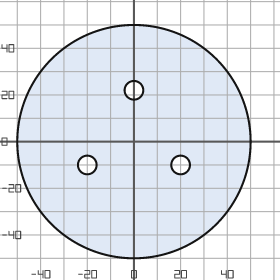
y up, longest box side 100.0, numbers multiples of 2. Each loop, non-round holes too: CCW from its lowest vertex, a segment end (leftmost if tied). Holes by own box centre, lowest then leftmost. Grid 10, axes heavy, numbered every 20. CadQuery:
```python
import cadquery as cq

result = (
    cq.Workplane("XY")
    .moveTo(0.0, 0.0)
    .circle(50.0)
    .moveTo(-20.0, -10.0)
    .circle(4.0)
    .moveTo(20.0, -10.0)
    .circle(4.0)
    .moveTo(0.0, 22.0)
    .circle(4.0)
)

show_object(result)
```